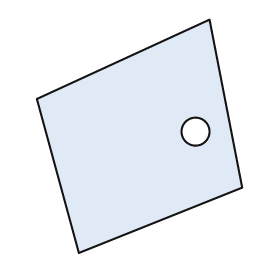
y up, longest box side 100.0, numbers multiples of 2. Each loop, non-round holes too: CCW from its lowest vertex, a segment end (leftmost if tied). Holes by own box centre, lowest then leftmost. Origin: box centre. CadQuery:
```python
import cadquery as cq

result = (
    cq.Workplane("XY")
    .moveTo(-26.0, -50.0)
    .lineTo(44.0, -22.0)
    .lineTo(30.0, 50.0)
    .lineTo(-44.0, 16.0)
    .close()
    .moveTo(24.0, 2.0)
    .circle(6.0)
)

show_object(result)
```